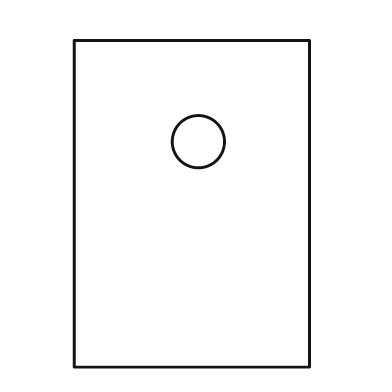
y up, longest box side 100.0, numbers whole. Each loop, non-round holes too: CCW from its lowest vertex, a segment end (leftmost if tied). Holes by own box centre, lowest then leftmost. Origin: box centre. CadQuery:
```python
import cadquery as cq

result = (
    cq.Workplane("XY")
    .moveTo(-36.0, -50.0)
    .lineTo(36.0, -50.0)
    .lineTo(36.0, 50.0)
    .lineTo(-36.0, 50.0)
    .close()
    .moveTo(2.0, 19.0)
    .circle(8.0)
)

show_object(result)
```